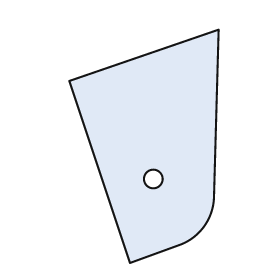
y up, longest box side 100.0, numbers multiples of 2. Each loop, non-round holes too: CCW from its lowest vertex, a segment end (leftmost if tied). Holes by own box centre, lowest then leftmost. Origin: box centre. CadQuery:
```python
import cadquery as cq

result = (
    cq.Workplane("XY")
    .moveTo(-6.0, -50.0)
    .lineTo(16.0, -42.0)
    .threePointArc((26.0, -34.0), (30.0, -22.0))
    .lineTo(32.0, 50.0)
    .lineTo(-32.0, 28.0)
    .close()
    .moveTo(4.0, -14.0)
    .circle(4.0)
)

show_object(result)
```